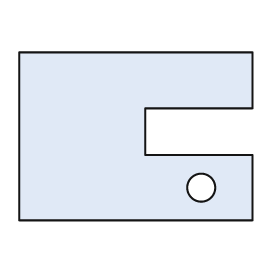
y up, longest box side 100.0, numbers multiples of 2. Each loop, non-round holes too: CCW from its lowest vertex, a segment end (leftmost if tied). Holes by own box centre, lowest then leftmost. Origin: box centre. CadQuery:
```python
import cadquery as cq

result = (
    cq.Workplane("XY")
    .moveTo(-50.0, -36.0)
    .lineTo(50.0, -36.0)
    .lineTo(50.0, -8.0)
    .lineTo(4.0, -8.0)
    .lineTo(4.0, 12.0)
    .lineTo(50.0, 12.0)
    .lineTo(50.0, 36.0)
    .lineTo(-50.0, 36.0)
    .close()
    .moveTo(28.0, -22.0)
    .circle(6.0)
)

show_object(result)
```